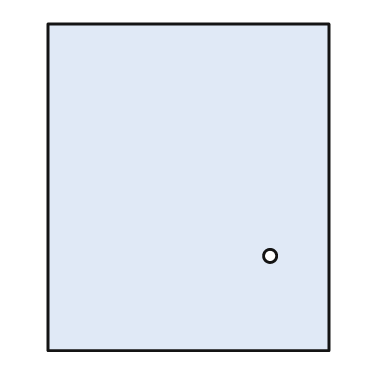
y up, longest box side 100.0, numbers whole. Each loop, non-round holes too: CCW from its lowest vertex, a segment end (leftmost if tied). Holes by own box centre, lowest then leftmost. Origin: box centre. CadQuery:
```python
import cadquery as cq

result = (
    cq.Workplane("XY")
    .moveTo(-43.0, -50.0)
    .lineTo(43.0, -50.0)
    .lineTo(43.0, 50.0)
    .lineTo(-43.0, 50.0)
    .close()
    .moveTo(25.0, -21.0)
    .circle(2.0)
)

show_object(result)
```